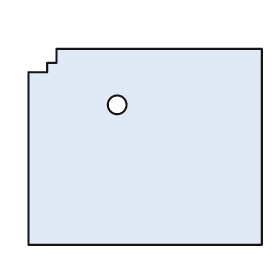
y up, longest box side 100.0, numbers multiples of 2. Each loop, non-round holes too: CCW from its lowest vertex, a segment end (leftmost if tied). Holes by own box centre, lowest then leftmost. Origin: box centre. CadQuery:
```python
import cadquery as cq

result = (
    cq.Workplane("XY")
    .moveTo(-50.0, -42.0)
    .lineTo(50.0, -42.0)
    .lineTo(50.0, 42.0)
    .lineTo(-38.0, 42.0)
    .lineTo(-38.0, 36.0)
    .lineTo(-42.0, 36.0)
    .lineTo(-42.0, 32.0)
    .lineTo(-50.0, 32.0)
    .close()
    .moveTo(-12.0, 18.0)
    .circle(4.0)
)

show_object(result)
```